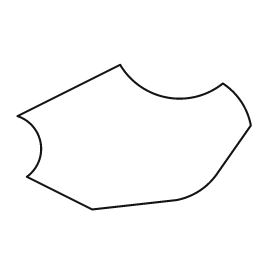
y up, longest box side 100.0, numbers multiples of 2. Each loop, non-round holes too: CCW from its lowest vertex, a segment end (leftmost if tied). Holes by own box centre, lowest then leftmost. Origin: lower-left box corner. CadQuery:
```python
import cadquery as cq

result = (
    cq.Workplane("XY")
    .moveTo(32.0, 0.0)
    .lineTo(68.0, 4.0)
    .threePointArc((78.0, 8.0), (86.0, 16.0))
    .lineTo(100.0, 36.0)
    .threePointArc((96.0, 46.0), (88.0, 54.0))
    .threePointArc((64.0, 48.0), (44.0, 62.0))
    .lineTo(0.0, 40.0)
    .threePointArc((10.0, 28.0), (4.0, 14.0))
    .close()
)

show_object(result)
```